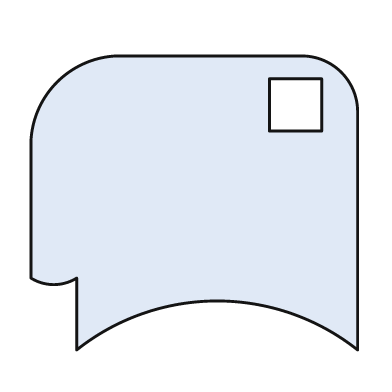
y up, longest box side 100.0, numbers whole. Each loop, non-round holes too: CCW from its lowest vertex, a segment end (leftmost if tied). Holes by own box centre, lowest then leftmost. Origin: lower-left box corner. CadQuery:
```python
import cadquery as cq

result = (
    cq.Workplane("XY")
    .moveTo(14.0, 0.0)
    .threePointArc((57.0, 15.0), (100.0, 0.0))
    .lineTo(100.0, 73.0)
    .threePointArc((95.0, 85.0), (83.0, 90.0))
    .lineTo(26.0, 90.0)
    .threePointArc((8.0, 82.0), (0.0, 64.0))
    .lineTo(0.0, 22.0)
    .threePointArc((7.0, 20.0), (14.0, 22.0))
    .close()
    .moveTo(73.0, 67.0)
    .lineTo(89.0, 67.0)
    .lineTo(89.0, 83.0)
    .lineTo(73.0, 83.0)
    .close()
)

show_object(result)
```